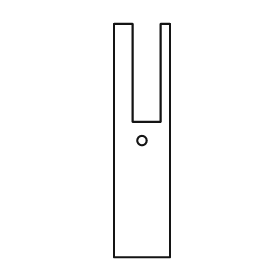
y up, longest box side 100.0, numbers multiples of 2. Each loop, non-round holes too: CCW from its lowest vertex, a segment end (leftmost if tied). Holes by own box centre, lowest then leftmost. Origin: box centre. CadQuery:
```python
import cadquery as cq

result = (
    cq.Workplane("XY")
    .moveTo(-12.0, -50.0)
    .lineTo(12.0, -50.0)
    .lineTo(12.0, 50.0)
    .lineTo(8.0, 50.0)
    .lineTo(8.0, 8.0)
    .lineTo(-4.0, 8.0)
    .lineTo(-4.0, 50.0)
    .lineTo(-12.0, 50.0)
    .close()
    .moveTo(0.0, 0.0)
    .circle(2.0)
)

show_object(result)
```